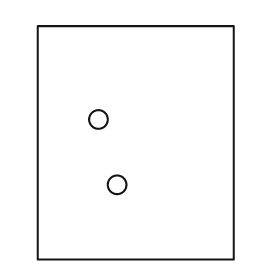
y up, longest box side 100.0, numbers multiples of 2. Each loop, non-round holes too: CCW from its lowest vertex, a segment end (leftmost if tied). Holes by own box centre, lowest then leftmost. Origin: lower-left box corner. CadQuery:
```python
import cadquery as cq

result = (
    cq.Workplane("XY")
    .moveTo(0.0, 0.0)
    .lineTo(84.0, 0.0)
    .lineTo(84.0, 100.0)
    .lineTo(0.0, 100.0)
    .close()
    .moveTo(34.0, 32.0)
    .circle(4.0)
    .moveTo(26.0, 60.0)
    .circle(4.0)
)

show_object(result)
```